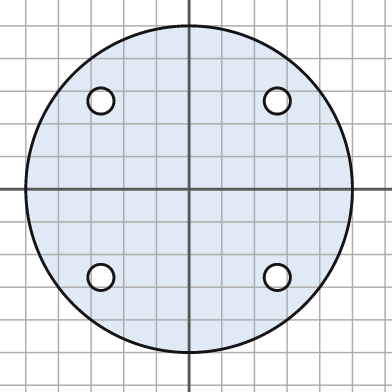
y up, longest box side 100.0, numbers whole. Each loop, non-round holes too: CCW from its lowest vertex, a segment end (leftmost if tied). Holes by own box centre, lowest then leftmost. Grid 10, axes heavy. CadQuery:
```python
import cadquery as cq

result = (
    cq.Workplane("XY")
    .moveTo(0.0, 0.0)
    .circle(50.0)
    .moveTo(-27.0, -27.0)
    .circle(4.0)
    .moveTo(27.0, -27.0)
    .circle(4.0)
    .moveTo(-27.0, 27.0)
    .circle(4.0)
    .moveTo(27.0, 27.0)
    .circle(4.0)
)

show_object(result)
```